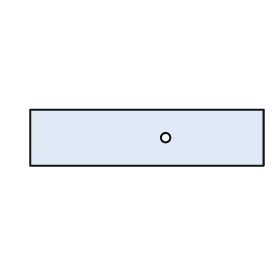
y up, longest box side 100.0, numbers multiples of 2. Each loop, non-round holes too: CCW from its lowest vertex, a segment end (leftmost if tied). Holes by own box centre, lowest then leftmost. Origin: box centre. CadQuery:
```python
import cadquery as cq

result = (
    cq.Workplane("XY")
    .moveTo(-50.0, -12.0)
    .lineTo(50.0, -12.0)
    .lineTo(50.0, 12.0)
    .lineTo(-50.0, 12.0)
    .close()
    .moveTo(8.0, 0.0)
    .circle(2.0)
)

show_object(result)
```